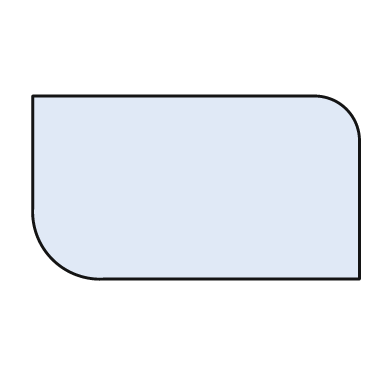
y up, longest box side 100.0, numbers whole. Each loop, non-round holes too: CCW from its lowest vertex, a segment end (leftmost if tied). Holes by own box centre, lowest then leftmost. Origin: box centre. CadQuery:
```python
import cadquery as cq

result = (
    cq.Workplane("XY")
    .moveTo(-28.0, -28.0)
    .lineTo(50.0, -28.0)
    .lineTo(50.0, 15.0)
    .threePointArc((46.0, 24.0), (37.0, 28.0))
    .lineTo(-50.0, 28.0)
    .lineTo(-50.0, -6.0)
    .threePointArc((-44.0, -22.0), (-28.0, -28.0))
    .close()
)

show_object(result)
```